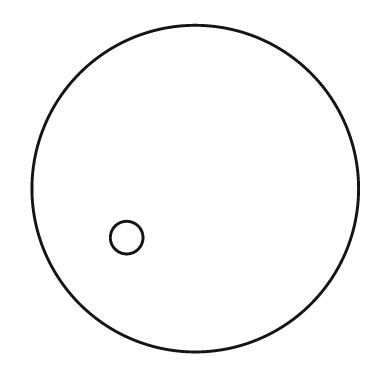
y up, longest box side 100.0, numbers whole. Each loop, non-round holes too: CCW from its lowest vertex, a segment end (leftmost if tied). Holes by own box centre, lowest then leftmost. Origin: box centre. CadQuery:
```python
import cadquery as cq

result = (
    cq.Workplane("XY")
    .moveTo(0.0, 0.0)
    .circle(50.0)
    .moveTo(-21.0, -15.0)
    .circle(5.0)
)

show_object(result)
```